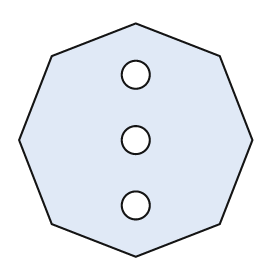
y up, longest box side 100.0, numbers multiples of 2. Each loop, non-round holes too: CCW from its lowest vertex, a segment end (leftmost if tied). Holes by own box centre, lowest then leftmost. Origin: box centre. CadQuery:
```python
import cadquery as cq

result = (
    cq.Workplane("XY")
    .moveTo(0.0, -50.0)
    .lineTo(36.0, -36.0)
    .lineTo(50.0, 0.0)
    .lineTo(36.0, 36.0)
    .lineTo(0.0, 50.0)
    .lineTo(-36.0, 36.0)
    .lineTo(-50.0, 0.0)
    .lineTo(-36.0, -36.0)
    .close()
    .moveTo(0.0, -28.0)
    .circle(6.0)
    .moveTo(0.0, 0.0)
    .circle(6.0)
    .moveTo(0.0, 28.0)
    .circle(6.0)
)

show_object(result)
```